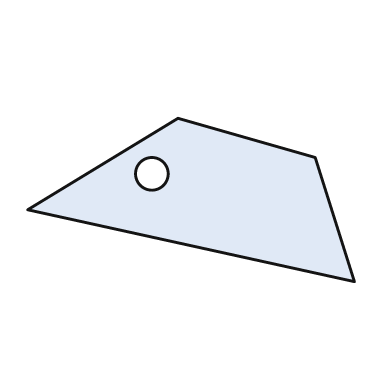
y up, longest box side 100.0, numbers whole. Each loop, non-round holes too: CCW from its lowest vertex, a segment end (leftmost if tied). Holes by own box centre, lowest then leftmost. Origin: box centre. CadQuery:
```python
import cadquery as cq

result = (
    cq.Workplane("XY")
    .moveTo(50.0, -25.0)
    .lineTo(38.0, 13.0)
    .lineTo(-4.0, 25.0)
    .lineTo(-50.0, -3.0)
    .close()
    .moveTo(-12.0, 8.0)
    .circle(5.0)
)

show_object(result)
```